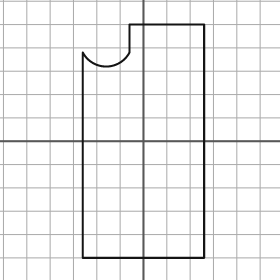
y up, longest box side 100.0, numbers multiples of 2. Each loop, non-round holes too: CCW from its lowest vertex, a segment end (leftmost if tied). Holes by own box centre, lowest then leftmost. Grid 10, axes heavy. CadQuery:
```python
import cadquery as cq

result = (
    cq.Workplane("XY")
    .moveTo(-26.0, -50.0)
    .lineTo(26.0, -50.0)
    .lineTo(26.0, 50.0)
    .lineTo(-6.0, 50.0)
    .lineTo(-6.0, 38.0)
    .threePointArc((-16.0, 32.0), (-26.0, 38.0))
    .close()
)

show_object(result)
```